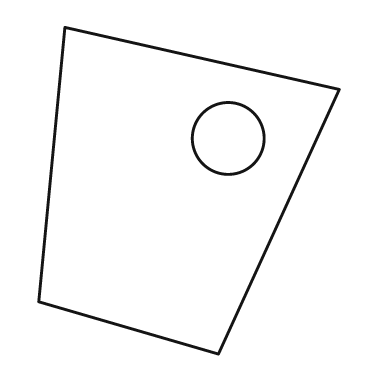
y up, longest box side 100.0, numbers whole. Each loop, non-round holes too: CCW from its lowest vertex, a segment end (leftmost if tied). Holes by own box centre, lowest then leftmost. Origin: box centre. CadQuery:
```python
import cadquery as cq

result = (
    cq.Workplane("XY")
    .moveTo(9.0, -50.0)
    .lineTo(46.0, 31.0)
    .lineTo(-38.0, 50.0)
    .lineTo(-46.0, -34.0)
    .close()
    .moveTo(12.0, 16.0)
    .circle(11.0)
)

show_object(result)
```